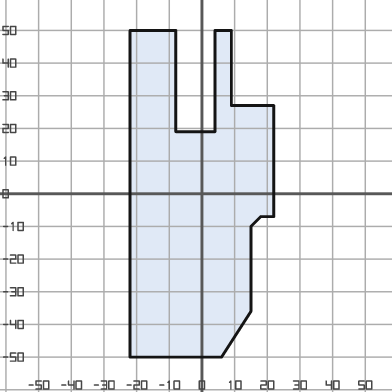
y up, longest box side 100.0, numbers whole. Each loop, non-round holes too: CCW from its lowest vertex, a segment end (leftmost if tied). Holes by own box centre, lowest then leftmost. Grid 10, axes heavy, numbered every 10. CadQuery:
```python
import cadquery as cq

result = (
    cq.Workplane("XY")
    .moveTo(-22.0, -50.0)
    .lineTo(6.0, -50.0)
    .lineTo(15.0, -36.0)
    .lineTo(15.0, -10.0)
    .lineTo(18.0, -7.0)
    .lineTo(22.0, -7.0)
    .lineTo(22.0, 27.0)
    .lineTo(9.0, 27.0)
    .lineTo(9.0, 50.0)
    .lineTo(4.0, 50.0)
    .lineTo(4.0, 19.0)
    .lineTo(-8.0, 19.0)
    .lineTo(-8.0, 50.0)
    .lineTo(-22.0, 50.0)
    .close()
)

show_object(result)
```